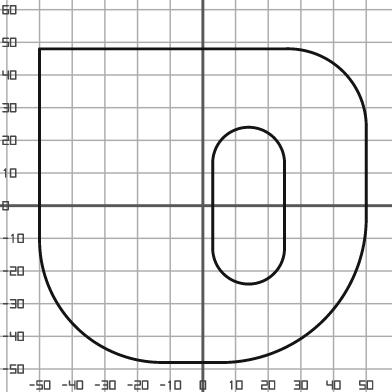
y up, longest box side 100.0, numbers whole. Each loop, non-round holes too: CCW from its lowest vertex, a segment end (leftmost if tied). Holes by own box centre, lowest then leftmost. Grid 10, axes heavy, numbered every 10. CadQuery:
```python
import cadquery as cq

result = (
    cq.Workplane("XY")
    .moveTo(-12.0, -48.0)
    .lineTo(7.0, -48.0)
    .threePointArc((37.0, -35.0), (50.0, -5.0))
    .lineTo(50.0, 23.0)
    .threePointArc((43.0, 41.0), (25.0, 48.0))
    .lineTo(-50.0, 48.0)
    .lineTo(-50.0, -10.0)
    .threePointArc((-39.0, -37.0), (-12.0, -48.0))
    .close()
    .moveTo(3.0, -13.0)
    .threePointArc((14.0, -24.0), (25.0, -13.0))
    .lineTo(25.0, 13.0)
    .threePointArc((14.0, 24.0), (3.0, 13.0))
    .close()
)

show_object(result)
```